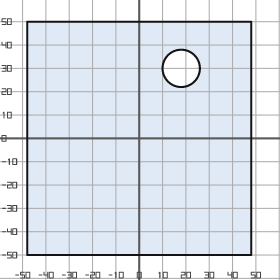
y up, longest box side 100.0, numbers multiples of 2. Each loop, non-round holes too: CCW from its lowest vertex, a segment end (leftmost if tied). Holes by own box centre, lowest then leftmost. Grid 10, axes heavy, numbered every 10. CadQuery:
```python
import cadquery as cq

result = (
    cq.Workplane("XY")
    .moveTo(-48.0, -50.0)
    .lineTo(48.0, -50.0)
    .lineTo(48.0, 50.0)
    .lineTo(-48.0, 50.0)
    .close()
    .moveTo(18.0, 30.0)
    .circle(8.0)
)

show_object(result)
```